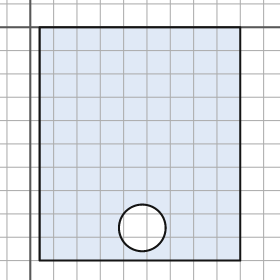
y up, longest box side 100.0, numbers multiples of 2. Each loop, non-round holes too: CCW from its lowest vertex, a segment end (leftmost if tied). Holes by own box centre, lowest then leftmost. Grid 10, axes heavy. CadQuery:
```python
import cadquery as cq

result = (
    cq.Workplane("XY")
    .moveTo(4.0, -100.0)
    .lineTo(90.0, -100.0)
    .lineTo(90.0, 0.0)
    .lineTo(4.0, 0.0)
    .close()
    .moveTo(48.0, -86.0)
    .circle(10.0)
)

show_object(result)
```